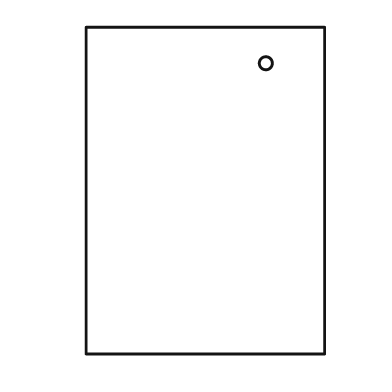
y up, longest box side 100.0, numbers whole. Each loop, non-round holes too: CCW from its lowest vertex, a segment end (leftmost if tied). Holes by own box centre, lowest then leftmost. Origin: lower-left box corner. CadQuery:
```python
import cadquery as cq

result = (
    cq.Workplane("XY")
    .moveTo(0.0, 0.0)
    .lineTo(73.0, 0.0)
    .lineTo(73.0, 100.0)
    .lineTo(0.0, 100.0)
    .close()
    .moveTo(55.0, 89.0)
    .circle(2.0)
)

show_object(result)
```